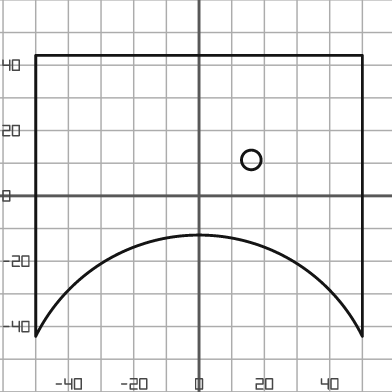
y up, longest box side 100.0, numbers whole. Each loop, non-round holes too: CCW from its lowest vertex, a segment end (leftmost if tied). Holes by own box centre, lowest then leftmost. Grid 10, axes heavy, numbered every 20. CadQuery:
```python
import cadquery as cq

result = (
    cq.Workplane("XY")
    .moveTo(-50.0, -43.0)
    .threePointArc((0.0, -12.0), (50.0, -43.0))
    .lineTo(50.0, 43.0)
    .lineTo(-50.0, 43.0)
    .close()
    .moveTo(16.0, 11.0)
    .circle(3.0)
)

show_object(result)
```